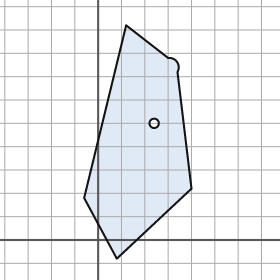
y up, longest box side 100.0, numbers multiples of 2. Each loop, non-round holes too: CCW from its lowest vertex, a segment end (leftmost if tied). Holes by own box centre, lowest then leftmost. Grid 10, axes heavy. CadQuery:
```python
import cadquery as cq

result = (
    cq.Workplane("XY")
    .moveTo(8.0, -8.0)
    .lineTo(40.0, 22.0)
    .lineTo(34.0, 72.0)
    .threePointArc((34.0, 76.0), (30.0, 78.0))
    .lineTo(12.0, 92.0)
    .lineTo(-6.0, 18.0)
    .close()
    .moveTo(24.0, 50.0)
    .circle(2.0)
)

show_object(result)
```